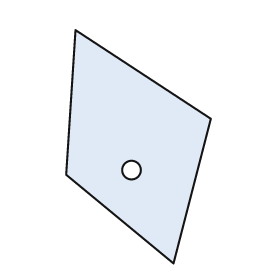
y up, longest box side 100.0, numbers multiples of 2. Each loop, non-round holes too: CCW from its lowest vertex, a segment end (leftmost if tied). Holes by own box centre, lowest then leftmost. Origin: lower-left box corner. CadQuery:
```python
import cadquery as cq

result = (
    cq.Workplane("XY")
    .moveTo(46.0, 0.0)
    .lineTo(62.0, 62.0)
    .lineTo(4.0, 100.0)
    .lineTo(0.0, 38.0)
    .close()
    .moveTo(28.0, 40.0)
    .circle(4.0)
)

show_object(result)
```